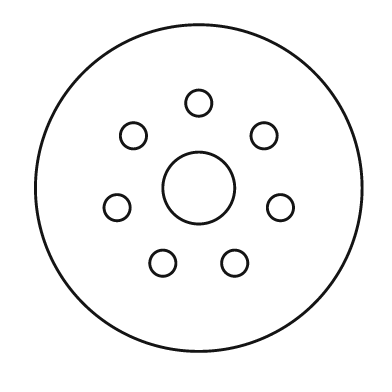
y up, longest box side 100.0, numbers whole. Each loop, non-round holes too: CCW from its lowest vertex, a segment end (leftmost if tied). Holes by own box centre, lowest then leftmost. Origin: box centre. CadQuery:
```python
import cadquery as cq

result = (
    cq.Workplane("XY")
    .moveTo(0.0, 0.0)
    .circle(50.0)
    .moveTo(-11.0, -23.0)
    .circle(4.0)
    .moveTo(11.0, -23.0)
    .circle(4.0)
    .moveTo(-25.0, -6.0)
    .circle(4.0)
    .moveTo(25.0, -6.0)
    .circle(4.0)
    .moveTo(0.0, 0.0)
    .circle(11.0)
    .moveTo(-20.0, 16.0)
    .circle(4.0)
    .moveTo(20.0, 16.0)
    .circle(4.0)
    .moveTo(0.0, 26.0)
    .circle(4.0)
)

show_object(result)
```